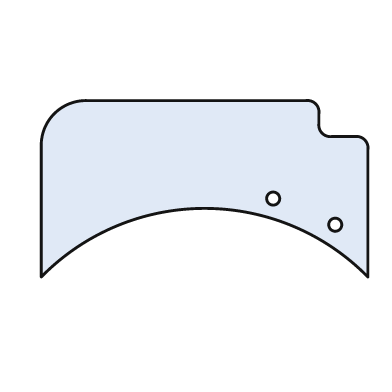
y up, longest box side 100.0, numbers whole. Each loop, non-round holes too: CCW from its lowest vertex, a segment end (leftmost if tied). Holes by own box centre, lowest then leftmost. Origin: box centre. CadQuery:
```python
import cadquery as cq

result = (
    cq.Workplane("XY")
    .moveTo(-50.0, -27.0)
    .threePointArc((0.0, -6.0), (50.0, -27.0))
    .lineTo(50.0, 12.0)
    .threePointArc((49.0, 15.0), (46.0, 16.0))
    .lineTo(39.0, 16.0)
    .threePointArc((36.0, 17.0), (35.0, 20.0))
    .lineTo(35.0, 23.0)
    .threePointArc((34.0, 26.0), (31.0, 27.0))
    .lineTo(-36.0, 27.0)
    .threePointArc((-46.0, 23.0), (-50.0, 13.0))
    .close()
    .moveTo(40.0, -11.0)
    .circle(2.0)
    .moveTo(21.0, -3.0)
    .circle(2.0)
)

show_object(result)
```